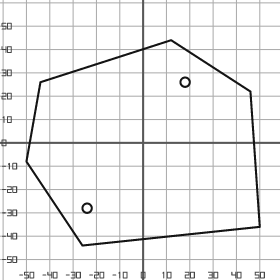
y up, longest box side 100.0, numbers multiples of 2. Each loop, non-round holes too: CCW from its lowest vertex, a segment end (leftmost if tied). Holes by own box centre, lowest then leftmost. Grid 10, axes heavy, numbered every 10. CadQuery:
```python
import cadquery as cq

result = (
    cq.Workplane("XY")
    .moveTo(-26.0, -44.0)
    .lineTo(50.0, -36.0)
    .lineTo(46.0, 22.0)
    .lineTo(12.0, 44.0)
    .lineTo(-44.0, 26.0)
    .lineTo(-50.0, -8.0)
    .close()
    .moveTo(-24.0, -28.0)
    .circle(2.0)
    .moveTo(18.0, 26.0)
    .circle(2.0)
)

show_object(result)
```